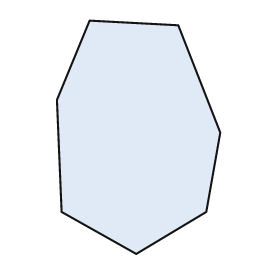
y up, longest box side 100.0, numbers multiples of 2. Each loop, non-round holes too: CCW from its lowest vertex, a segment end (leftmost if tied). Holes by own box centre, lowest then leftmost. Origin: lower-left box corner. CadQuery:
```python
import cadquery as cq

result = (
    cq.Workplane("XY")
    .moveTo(34.0, 0.0)
    .lineTo(64.0, 18.0)
    .lineTo(70.0, 52.0)
    .lineTo(52.0, 98.0)
    .lineTo(14.0, 100.0)
    .lineTo(0.0, 66.0)
    .lineTo(2.0, 18.0)
    .close()
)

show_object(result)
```